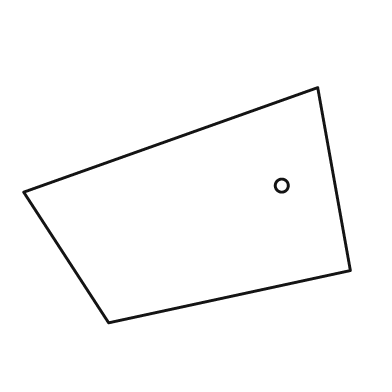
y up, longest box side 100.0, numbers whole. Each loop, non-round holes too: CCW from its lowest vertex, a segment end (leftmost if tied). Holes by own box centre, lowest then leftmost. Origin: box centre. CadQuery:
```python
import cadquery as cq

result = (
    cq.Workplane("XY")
    .moveTo(-24.0, -36.0)
    .lineTo(50.0, -20.0)
    .lineTo(40.0, 36.0)
    .lineTo(-50.0, 4.0)
    .close()
    .moveTo(29.0, 6.0)
    .circle(2.0)
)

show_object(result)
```